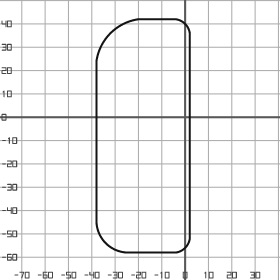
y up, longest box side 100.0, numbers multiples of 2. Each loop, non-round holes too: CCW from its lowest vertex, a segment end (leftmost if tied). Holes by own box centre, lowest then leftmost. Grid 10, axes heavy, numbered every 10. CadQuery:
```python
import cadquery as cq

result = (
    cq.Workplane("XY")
    .moveTo(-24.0, -58.0)
    .lineTo(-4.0, -58.0)
    .threePointArc((0.0, -56.0), (2.0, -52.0))
    .lineTo(2.0, 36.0)
    .threePointArc((0.0, 40.0), (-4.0, 42.0))
    .lineTo(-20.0, 42.0)
    .threePointArc((-32.0, 36.0), (-38.0, 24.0))
    .lineTo(-38.0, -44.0)
    .threePointArc((-34.0, -54.0), (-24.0, -58.0))
    .close()
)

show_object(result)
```